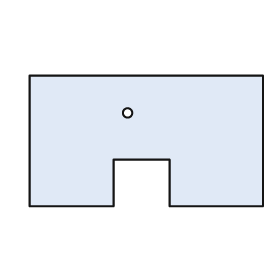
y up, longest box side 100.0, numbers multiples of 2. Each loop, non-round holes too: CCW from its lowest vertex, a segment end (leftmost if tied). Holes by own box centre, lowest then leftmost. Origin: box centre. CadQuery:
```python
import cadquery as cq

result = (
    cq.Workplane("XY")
    .moveTo(-50.0, -28.0)
    .lineTo(-14.0, -28.0)
    .lineTo(-14.0, -8.0)
    .lineTo(10.0, -8.0)
    .lineTo(10.0, -28.0)
    .lineTo(50.0, -28.0)
    .lineTo(50.0, 28.0)
    .lineTo(-50.0, 28.0)
    .close()
    .moveTo(-8.0, 12.0)
    .circle(2.0)
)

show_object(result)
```